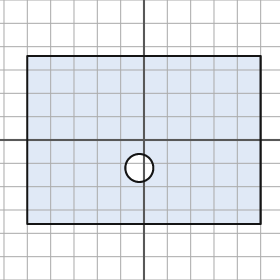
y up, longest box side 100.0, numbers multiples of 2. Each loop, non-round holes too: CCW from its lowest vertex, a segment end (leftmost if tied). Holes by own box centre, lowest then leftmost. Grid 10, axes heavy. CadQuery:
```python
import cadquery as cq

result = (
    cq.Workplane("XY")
    .moveTo(-50.0, -36.0)
    .lineTo(50.0, -36.0)
    .lineTo(50.0, 36.0)
    .lineTo(-50.0, 36.0)
    .close()
    .moveTo(-2.0, -12.0)
    .circle(6.0)
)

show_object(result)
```